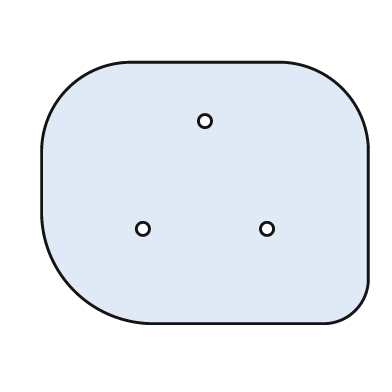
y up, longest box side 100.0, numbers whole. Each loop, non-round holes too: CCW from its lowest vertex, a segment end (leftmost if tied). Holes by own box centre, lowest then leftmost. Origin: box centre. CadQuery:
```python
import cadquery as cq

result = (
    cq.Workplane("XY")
    .moveTo(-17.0, -40.0)
    .lineTo(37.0, -40.0)
    .threePointArc((46.0, -36.0), (50.0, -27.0))
    .lineTo(50.0, 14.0)
    .threePointArc((42.0, 32.0), (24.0, 40.0))
    .lineTo(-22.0, 40.0)
    .threePointArc((-42.0, 32.0), (-50.0, 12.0))
    .lineTo(-50.0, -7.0)
    .threePointArc((-40.0, -30.0), (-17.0, -40.0))
    .close()
    .moveTo(-19.0, -11.0)
    .circle(2.0)
    .moveTo(19.0, -11.0)
    .circle(2.0)
    .moveTo(0.0, 22.0)
    .circle(2.0)
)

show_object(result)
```